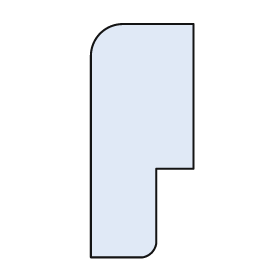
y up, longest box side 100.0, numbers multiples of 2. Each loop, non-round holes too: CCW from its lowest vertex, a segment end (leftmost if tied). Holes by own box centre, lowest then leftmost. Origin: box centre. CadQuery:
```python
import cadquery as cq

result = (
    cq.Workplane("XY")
    .moveTo(-22.0, -50.0)
    .lineTo(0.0, -50.0)
    .threePointArc((4.0, -48.0), (6.0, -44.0))
    .lineTo(6.0, -12.0)
    .lineTo(22.0, -12.0)
    .lineTo(22.0, 50.0)
    .lineTo(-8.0, 50.0)
    .threePointArc((-18.0, 46.0), (-22.0, 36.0))
    .close()
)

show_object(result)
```